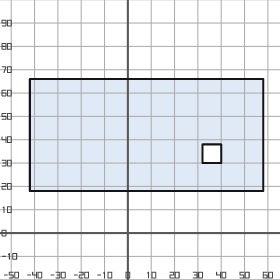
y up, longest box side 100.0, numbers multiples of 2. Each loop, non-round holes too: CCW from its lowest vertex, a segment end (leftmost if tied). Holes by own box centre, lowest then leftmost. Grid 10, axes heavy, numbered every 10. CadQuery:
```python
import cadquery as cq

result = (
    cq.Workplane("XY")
    .moveTo(-42.0, 18.0)
    .lineTo(58.0, 18.0)
    .lineTo(58.0, 66.0)
    .lineTo(-42.0, 66.0)
    .close()
    .moveTo(32.0, 30.0)
    .lineTo(40.0, 30.0)
    .lineTo(40.0, 38.0)
    .lineTo(32.0, 38.0)
    .close()
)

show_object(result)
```